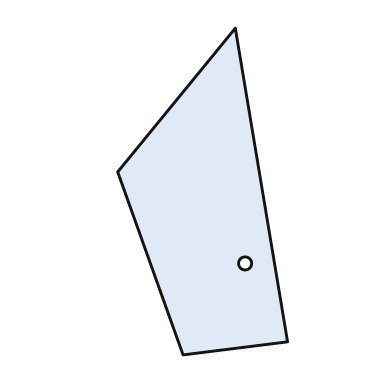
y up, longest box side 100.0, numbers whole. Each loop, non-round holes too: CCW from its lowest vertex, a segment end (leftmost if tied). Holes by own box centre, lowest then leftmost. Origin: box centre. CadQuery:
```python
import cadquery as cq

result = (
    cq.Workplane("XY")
    .moveTo(-6.0, -50.0)
    .lineTo(26.0, -46.0)
    .lineTo(10.0, 50.0)
    .lineTo(-26.0, 6.0)
    .close()
    .moveTo(13.0, -22.0)
    .circle(2.0)
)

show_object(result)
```